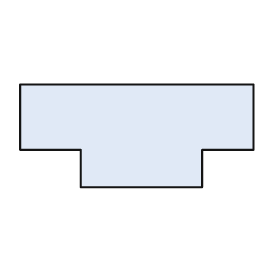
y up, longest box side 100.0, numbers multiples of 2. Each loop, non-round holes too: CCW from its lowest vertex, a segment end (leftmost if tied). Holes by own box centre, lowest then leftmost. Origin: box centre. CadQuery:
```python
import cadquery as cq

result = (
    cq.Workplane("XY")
    .moveTo(-24.0, -22.0)
    .lineTo(28.0, -22.0)
    .lineTo(28.0, -6.0)
    .lineTo(50.0, -6.0)
    .lineTo(50.0, 22.0)
    .lineTo(-50.0, 22.0)
    .lineTo(-50.0, -6.0)
    .lineTo(-24.0, -6.0)
    .close()
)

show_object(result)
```